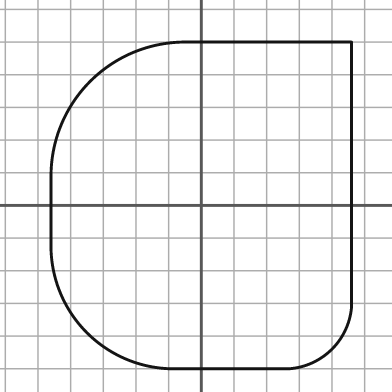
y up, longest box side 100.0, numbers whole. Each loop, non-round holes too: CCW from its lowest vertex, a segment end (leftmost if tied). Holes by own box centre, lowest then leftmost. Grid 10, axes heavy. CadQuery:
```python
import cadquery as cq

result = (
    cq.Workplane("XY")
    .moveTo(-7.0, -50.0)
    .lineTo(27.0, -50.0)
    .threePointArc((40.0, -44.0), (46.0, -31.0))
    .lineTo(46.0, 50.0)
    .lineTo(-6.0, 50.0)
    .threePointArc((-34.0, 38.0), (-46.0, 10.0))
    .lineTo(-46.0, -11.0)
    .threePointArc((-35.0, -39.0), (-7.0, -50.0))
    .close()
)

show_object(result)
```